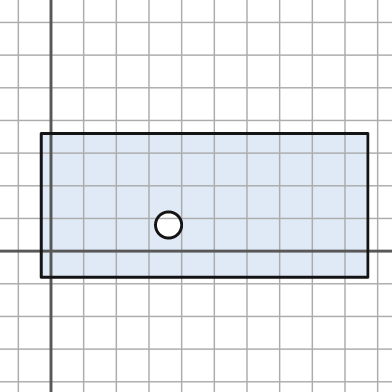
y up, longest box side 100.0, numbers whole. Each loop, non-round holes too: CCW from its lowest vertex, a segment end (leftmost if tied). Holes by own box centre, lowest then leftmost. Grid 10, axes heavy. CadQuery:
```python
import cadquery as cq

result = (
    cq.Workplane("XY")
    .moveTo(-3.0, -8.0)
    .lineTo(97.0, -8.0)
    .lineTo(97.0, 36.0)
    .lineTo(-3.0, 36.0)
    .close()
    .moveTo(36.0, 8.0)
    .circle(4.0)
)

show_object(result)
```